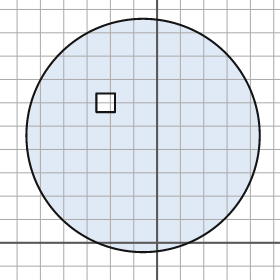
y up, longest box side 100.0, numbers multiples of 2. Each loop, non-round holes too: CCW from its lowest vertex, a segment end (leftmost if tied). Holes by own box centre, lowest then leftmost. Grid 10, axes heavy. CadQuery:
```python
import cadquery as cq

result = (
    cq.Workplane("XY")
    .moveTo(-6.0, 46.0)
    .circle(50.0)
    .moveTo(-26.0, 56.0)
    .lineTo(-18.0, 56.0)
    .lineTo(-18.0, 64.0)
    .lineTo(-26.0, 64.0)
    .close()
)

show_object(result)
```